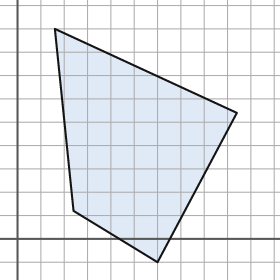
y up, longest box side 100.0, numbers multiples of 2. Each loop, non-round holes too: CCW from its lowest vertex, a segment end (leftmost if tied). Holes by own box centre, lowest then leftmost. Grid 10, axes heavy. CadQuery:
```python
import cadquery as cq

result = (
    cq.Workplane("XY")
    .moveTo(60.0, -10.0)
    .lineTo(94.0, 54.0)
    .lineTo(16.0, 90.0)
    .lineTo(24.0, 12.0)
    .close()
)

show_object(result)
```